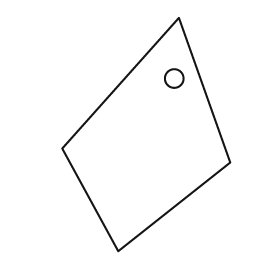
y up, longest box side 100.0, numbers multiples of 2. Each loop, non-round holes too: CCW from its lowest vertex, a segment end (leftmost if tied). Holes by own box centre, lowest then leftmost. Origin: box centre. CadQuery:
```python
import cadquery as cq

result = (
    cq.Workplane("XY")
    .moveTo(-12.0, -50.0)
    .lineTo(36.0, -12.0)
    .lineTo(14.0, 50.0)
    .lineTo(-36.0, -6.0)
    .close()
    .moveTo(12.0, 24.0)
    .circle(4.0)
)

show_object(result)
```